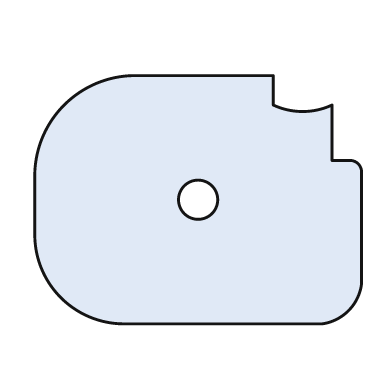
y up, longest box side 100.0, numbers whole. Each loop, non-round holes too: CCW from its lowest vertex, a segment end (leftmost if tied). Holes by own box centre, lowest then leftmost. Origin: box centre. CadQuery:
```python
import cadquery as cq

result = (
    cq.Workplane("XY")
    .moveTo(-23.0, -38.0)
    .lineTo(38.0, -38.0)
    .threePointArc((46.0, -34.0), (50.0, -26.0))
    .lineTo(50.0, 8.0)
    .threePointArc((49.0, 11.0), (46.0, 12.0))
    .lineTo(41.0, 12.0)
    .lineTo(41.0, 29.0)
    .threePointArc((32.0, 27.0), (23.0, 29.0))
    .lineTo(23.0, 38.0)
    .lineTo(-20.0, 38.0)
    .threePointArc((-41.0, 29.0), (-50.0, 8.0))
    .lineTo(-50.0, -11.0)
    .threePointArc((-42.0, -30.0), (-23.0, -38.0))
    .close()
    .moveTo(0.0, 0.0)
    .circle(6.0)
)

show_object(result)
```